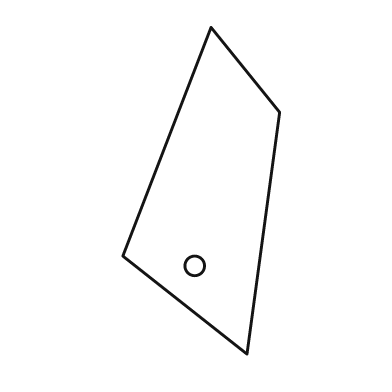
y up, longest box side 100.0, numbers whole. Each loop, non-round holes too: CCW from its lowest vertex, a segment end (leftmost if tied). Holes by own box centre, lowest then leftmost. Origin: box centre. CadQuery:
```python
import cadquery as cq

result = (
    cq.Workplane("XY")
    .moveTo(14.0, -50.0)
    .lineTo(24.0, 24.0)
    .lineTo(3.0, 50.0)
    .lineTo(-24.0, -20.0)
    .close()
    .moveTo(-2.0, -23.0)
    .circle(3.0)
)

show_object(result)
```